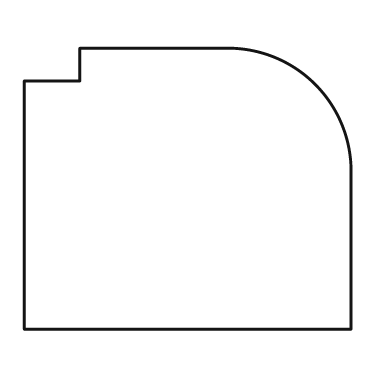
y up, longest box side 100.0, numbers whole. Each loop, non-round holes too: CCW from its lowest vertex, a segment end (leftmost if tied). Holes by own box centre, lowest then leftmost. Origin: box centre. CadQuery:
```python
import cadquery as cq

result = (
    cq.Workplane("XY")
    .moveTo(-50.0, -43.0)
    .lineTo(50.0, -43.0)
    .lineTo(50.0, 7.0)
    .threePointArc((39.0, 32.0), (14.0, 43.0))
    .lineTo(-33.0, 43.0)
    .lineTo(-33.0, 33.0)
    .lineTo(-50.0, 33.0)
    .close()
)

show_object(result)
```